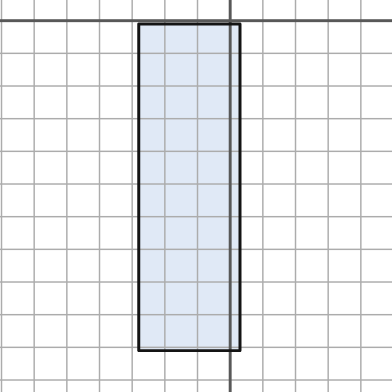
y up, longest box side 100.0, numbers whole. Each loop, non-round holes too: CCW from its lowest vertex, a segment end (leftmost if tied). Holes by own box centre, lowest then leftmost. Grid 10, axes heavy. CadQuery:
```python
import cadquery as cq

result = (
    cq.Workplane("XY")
    .moveTo(-28.0, -101.0)
    .lineTo(3.0, -101.0)
    .lineTo(3.0, -1.0)
    .lineTo(-28.0, -1.0)
    .close()
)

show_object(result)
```